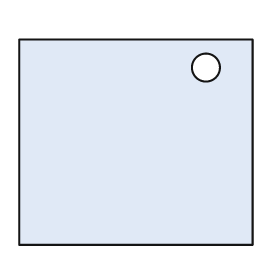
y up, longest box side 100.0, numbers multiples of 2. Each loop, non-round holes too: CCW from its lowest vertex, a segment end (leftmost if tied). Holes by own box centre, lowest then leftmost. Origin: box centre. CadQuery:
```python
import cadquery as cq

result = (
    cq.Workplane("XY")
    .moveTo(-50.0, -44.0)
    .lineTo(50.0, -44.0)
    .lineTo(50.0, 44.0)
    .lineTo(-50.0, 44.0)
    .close()
    .moveTo(30.0, 32.0)
    .circle(6.0)
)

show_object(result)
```